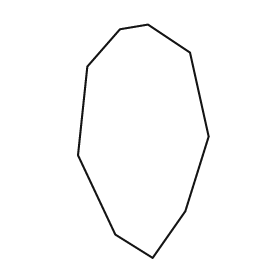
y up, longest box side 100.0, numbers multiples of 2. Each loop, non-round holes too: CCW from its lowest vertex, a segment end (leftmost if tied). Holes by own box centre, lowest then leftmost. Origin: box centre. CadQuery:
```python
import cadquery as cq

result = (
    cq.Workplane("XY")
    .moveTo(4.0, -50.0)
    .lineTo(18.0, -30.0)
    .lineTo(28.0, 2.0)
    .lineTo(20.0, 38.0)
    .lineTo(2.0, 50.0)
    .lineTo(-10.0, 48.0)
    .lineTo(-24.0, 32.0)
    .lineTo(-28.0, -6.0)
    .lineTo(-12.0, -40.0)
    .close()
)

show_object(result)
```